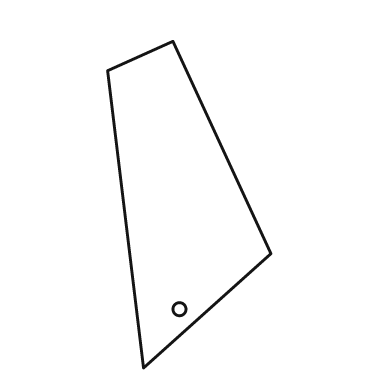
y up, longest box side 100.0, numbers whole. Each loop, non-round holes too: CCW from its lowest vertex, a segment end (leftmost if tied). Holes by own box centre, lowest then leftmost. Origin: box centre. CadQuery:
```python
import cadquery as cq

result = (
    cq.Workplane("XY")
    .moveTo(-14.0, -50.0)
    .lineTo(25.0, -15.0)
    .lineTo(-5.0, 50.0)
    .lineTo(-25.0, 41.0)
    .close()
    .moveTo(-3.0, -32.0)
    .circle(2.0)
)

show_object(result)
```